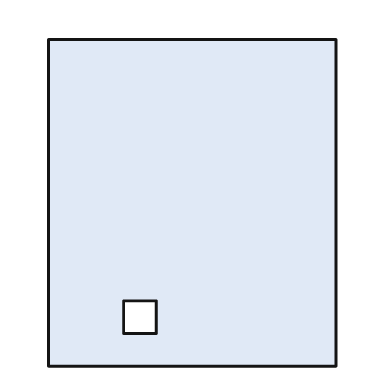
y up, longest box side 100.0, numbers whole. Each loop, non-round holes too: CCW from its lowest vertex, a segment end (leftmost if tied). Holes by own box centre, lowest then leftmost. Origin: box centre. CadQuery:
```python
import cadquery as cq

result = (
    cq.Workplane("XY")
    .moveTo(-44.0, -50.0)
    .lineTo(44.0, -50.0)
    .lineTo(44.0, 50.0)
    .lineTo(-44.0, 50.0)
    .close()
    .moveTo(-21.0, -40.0)
    .lineTo(-11.0, -40.0)
    .lineTo(-11.0, -30.0)
    .lineTo(-21.0, -30.0)
    .close()
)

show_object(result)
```